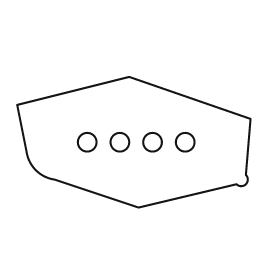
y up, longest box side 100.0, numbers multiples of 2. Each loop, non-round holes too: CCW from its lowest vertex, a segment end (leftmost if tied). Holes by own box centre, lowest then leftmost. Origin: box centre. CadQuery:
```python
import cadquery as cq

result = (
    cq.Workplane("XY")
    .moveTo(2.0, -28.0)
    .lineTo(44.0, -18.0)
    .threePointArc((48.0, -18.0), (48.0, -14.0))
    .lineTo(50.0, 10.0)
    .lineTo(-2.0, 28.0)
    .lineTo(-50.0, 16.0)
    .lineTo(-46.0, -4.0)
    .threePointArc((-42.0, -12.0), (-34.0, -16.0))
    .close()
    .moveTo(-20.0, 0.0)
    .circle(4.0)
    .moveTo(-6.0, 0.0)
    .circle(4.0)
    .moveTo(8.0, 0.0)
    .circle(4.0)
    .moveTo(22.0, 0.0)
    .circle(4.0)
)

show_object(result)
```